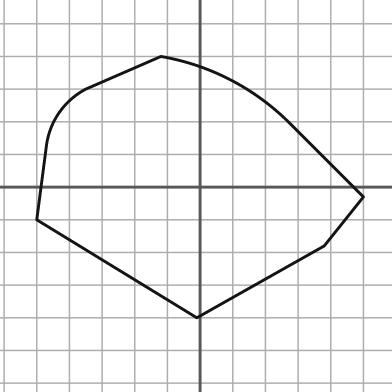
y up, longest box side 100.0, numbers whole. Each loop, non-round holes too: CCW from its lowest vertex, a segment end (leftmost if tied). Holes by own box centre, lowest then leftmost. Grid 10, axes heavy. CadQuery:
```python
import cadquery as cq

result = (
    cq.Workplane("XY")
    .moveTo(-1.0, -40.0)
    .lineTo(38.0, -18.0)
    .lineTo(50.0, -3.0)
    .lineTo(27.0, 20.0)
    .threePointArc((9.0, 33.0), (-12.0, 40.0))
    .lineTo(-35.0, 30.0)
    .threePointArc((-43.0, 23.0), (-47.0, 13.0))
    .lineTo(-50.0, -10.0)
    .close()
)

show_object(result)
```